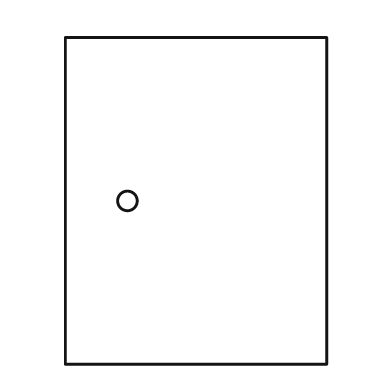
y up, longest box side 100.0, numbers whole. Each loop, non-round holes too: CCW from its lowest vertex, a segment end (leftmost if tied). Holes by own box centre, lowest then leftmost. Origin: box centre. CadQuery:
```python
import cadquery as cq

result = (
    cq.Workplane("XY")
    .moveTo(-40.0, -50.0)
    .lineTo(40.0, -50.0)
    .lineTo(40.0, 50.0)
    .lineTo(-40.0, 50.0)
    .close()
    .moveTo(-21.0, 0.0)
    .circle(3.0)
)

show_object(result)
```